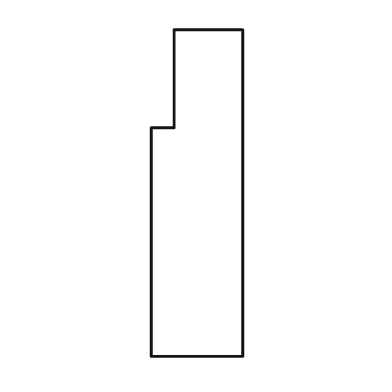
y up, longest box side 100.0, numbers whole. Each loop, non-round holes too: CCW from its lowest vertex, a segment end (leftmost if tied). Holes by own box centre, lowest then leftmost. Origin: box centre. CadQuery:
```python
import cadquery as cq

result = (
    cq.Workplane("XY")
    .moveTo(-14.0, -50.0)
    .lineTo(14.0, -50.0)
    .lineTo(14.0, 50.0)
    .lineTo(-7.0, 50.0)
    .lineTo(-7.0, 20.0)
    .lineTo(-14.0, 20.0)
    .close()
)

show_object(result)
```